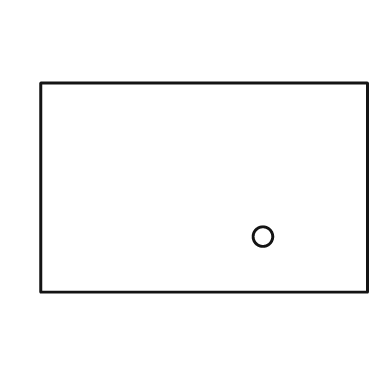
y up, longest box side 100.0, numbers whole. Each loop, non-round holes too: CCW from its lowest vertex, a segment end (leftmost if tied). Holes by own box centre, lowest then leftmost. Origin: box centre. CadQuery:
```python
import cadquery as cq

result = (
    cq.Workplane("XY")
    .moveTo(-50.0, -32.0)
    .lineTo(50.0, -32.0)
    .lineTo(50.0, 32.0)
    .lineTo(-50.0, 32.0)
    .close()
    .moveTo(18.0, -15.0)
    .circle(3.0)
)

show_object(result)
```